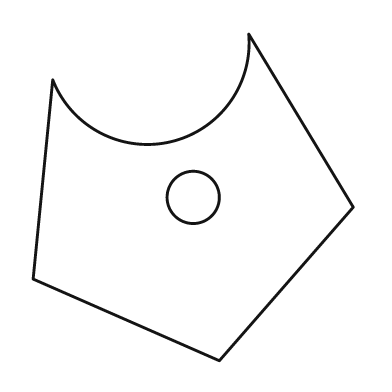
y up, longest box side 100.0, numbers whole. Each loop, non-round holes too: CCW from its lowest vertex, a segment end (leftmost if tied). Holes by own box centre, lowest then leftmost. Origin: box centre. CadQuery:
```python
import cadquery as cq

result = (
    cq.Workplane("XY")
    .moveTo(8.0, -50.0)
    .lineTo(49.0, -3.0)
    .lineTo(17.0, 50.0)
    .threePointArc((-7.0, 17.0), (-43.0, 36.0))
    .lineTo(-49.0, -25.0)
    .close()
    .moveTo(0.0, 0.0)
    .circle(8.0)
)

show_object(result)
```